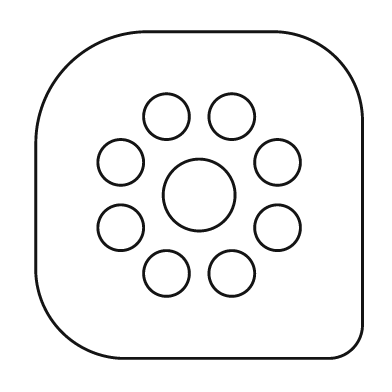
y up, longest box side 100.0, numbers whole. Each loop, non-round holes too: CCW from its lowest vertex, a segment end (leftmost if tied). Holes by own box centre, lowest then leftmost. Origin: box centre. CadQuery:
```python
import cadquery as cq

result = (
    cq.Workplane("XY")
    .moveTo(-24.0, -50.0)
    .lineTo(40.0, -50.0)
    .threePointArc((47.0, -47.0), (50.0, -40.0))
    .lineTo(50.0, 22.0)
    .threePointArc((42.0, 42.0), (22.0, 50.0))
    .lineTo(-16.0, 50.0)
    .threePointArc((-40.0, 40.0), (-50.0, 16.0))
    .lineTo(-50.0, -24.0)
    .threePointArc((-42.0, -42.0), (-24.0, -50.0))
    .close()
    .moveTo(-10.0, -24.0)
    .circle(7.0)
    .moveTo(10.0, -24.0)
    .circle(7.0)
    .moveTo(-24.0, -10.0)
    .circle(7.0)
    .moveTo(24.0, -10.0)
    .circle(7.0)
    .moveTo(0.0, 0.0)
    .circle(11.0)
    .moveTo(-24.0, 10.0)
    .circle(7.0)
    .moveTo(24.0, 10.0)
    .circle(7.0)
    .moveTo(-10.0, 24.0)
    .circle(7.0)
    .moveTo(10.0, 24.0)
    .circle(7.0)
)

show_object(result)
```